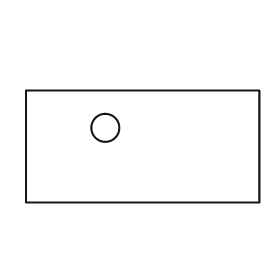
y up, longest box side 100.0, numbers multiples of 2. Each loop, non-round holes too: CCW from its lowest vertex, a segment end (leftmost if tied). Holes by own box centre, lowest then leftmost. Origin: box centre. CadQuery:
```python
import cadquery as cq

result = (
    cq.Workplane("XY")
    .moveTo(-50.0, -24.0)
    .lineTo(50.0, -24.0)
    .lineTo(50.0, 24.0)
    .lineTo(-50.0, 24.0)
    .close()
    .moveTo(-16.0, 8.0)
    .circle(6.0)
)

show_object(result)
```